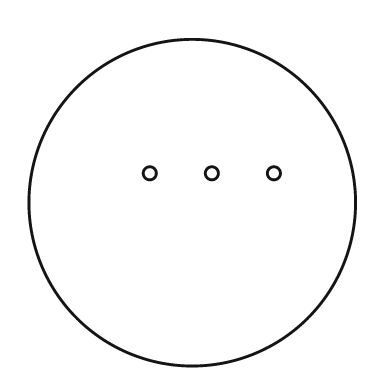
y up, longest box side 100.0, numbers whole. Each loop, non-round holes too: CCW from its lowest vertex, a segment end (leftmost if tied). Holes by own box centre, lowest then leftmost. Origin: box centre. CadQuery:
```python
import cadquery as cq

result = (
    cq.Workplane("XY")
    .moveTo(0.0, 0.0)
    .circle(50.0)
    .moveTo(-13.0, 9.0)
    .circle(2.0)
    .moveTo(6.0, 9.0)
    .circle(2.0)
    .moveTo(25.0, 9.0)
    .circle(2.0)
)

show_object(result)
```